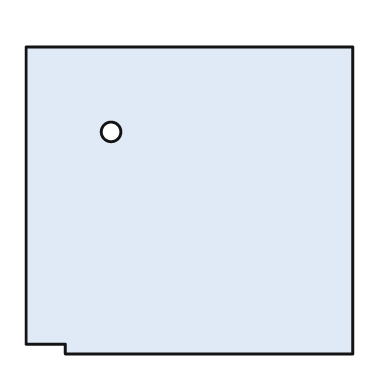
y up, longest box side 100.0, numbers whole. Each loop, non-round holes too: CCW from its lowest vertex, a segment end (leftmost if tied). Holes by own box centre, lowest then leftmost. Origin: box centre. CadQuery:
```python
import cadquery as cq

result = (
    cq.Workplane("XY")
    .moveTo(-38.0, -47.0)
    .lineTo(50.0, -47.0)
    .lineTo(50.0, 47.0)
    .lineTo(-50.0, 47.0)
    .lineTo(-50.0, -44.0)
    .lineTo(-38.0, -44.0)
    .close()
    .moveTo(-24.0, 21.0)
    .circle(3.0)
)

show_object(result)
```